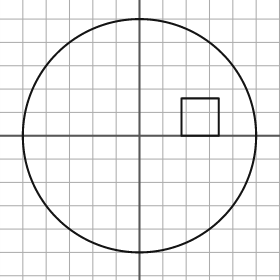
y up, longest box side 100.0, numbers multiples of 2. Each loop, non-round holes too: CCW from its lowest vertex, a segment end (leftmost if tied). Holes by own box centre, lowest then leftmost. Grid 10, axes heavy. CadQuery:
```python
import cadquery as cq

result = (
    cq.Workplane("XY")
    .moveTo(0.0, 0.0)
    .circle(50.0)
    .moveTo(18.0, 0.0)
    .lineTo(34.0, 0.0)
    .lineTo(34.0, 16.0)
    .lineTo(18.0, 16.0)
    .close()
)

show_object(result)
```